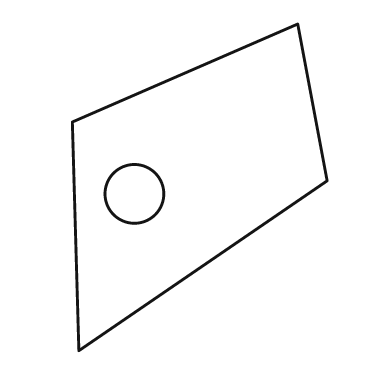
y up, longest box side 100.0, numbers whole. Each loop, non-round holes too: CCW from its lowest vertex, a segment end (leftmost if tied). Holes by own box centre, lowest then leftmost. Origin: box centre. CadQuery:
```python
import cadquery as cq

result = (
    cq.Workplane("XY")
    .moveTo(-37.0, -50.0)
    .lineTo(39.0, 2.0)
    .lineTo(30.0, 50.0)
    .lineTo(-39.0, 20.0)
    .close()
    .moveTo(-20.0, -2.0)
    .circle(9.0)
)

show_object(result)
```